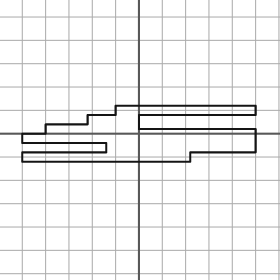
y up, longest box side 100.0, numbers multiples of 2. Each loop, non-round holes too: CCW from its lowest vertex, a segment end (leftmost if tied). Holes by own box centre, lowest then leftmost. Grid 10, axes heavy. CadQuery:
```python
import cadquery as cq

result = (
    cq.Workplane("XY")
    .moveTo(-50.0, -12.0)
    .lineTo(22.0, -12.0)
    .lineTo(22.0, -8.0)
    .lineTo(50.0, -8.0)
    .lineTo(50.0, 2.0)
    .lineTo(0.0, 2.0)
    .lineTo(0.0, 8.0)
    .lineTo(50.0, 8.0)
    .lineTo(50.0, 12.0)
    .lineTo(-10.0, 12.0)
    .lineTo(-10.0, 8.0)
    .lineTo(-22.0, 8.0)
    .lineTo(-22.0, 4.0)
    .lineTo(-40.0, 4.0)
    .lineTo(-40.0, 0.0)
    .lineTo(-50.0, 0.0)
    .lineTo(-50.0, -4.0)
    .lineTo(-14.0, -4.0)
    .lineTo(-14.0, -8.0)
    .lineTo(-50.0, -8.0)
    .close()
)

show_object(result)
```